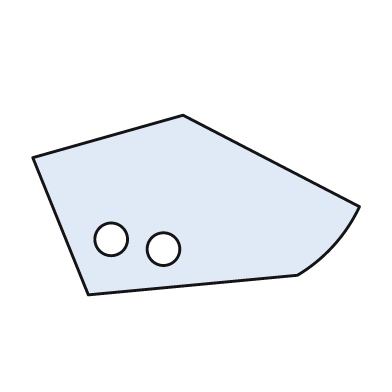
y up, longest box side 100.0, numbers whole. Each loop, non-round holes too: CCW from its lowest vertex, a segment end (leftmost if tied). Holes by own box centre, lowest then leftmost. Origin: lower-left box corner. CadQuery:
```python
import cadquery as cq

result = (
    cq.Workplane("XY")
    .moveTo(17.0, 0.0)
    .lineTo(81.0, 6.0)
    .threePointArc((92.0, 15.0), (100.0, 27.0))
    .lineTo(46.0, 55.0)
    .lineTo(0.0, 42.0)
    .close()
    .moveTo(40.0, 14.0)
    .circle(5.0)
    .moveTo(24.0, 17.0)
    .circle(5.0)
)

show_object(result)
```